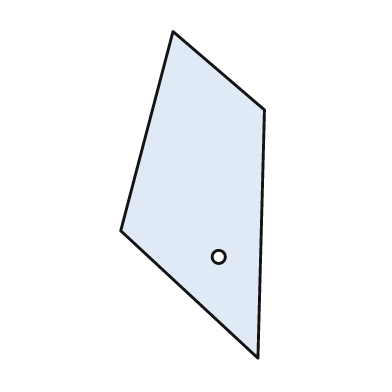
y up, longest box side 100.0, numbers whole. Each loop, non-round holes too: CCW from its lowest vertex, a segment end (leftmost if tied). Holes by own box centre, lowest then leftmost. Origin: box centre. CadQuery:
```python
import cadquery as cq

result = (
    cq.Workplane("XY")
    .moveTo(20.0, -50.0)
    .lineTo(22.0, 26.0)
    .lineTo(-6.0, 50.0)
    .lineTo(-22.0, -11.0)
    .close()
    .moveTo(8.0, -19.0)
    .circle(2.0)
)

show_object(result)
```